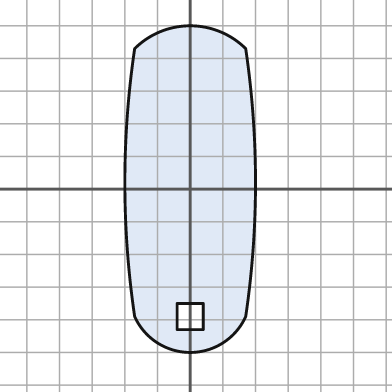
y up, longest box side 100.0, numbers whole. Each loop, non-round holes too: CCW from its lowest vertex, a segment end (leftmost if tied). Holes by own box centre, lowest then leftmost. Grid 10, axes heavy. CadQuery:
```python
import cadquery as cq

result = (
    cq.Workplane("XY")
    .moveTo(-17.0, -39.0)
    .threePointArc((0.0, -50.0), (17.0, -39.0))
    .threePointArc((20.0, 2.0), (17.0, 43.0))
    .threePointArc((0.0, 50.0), (-17.0, 43.0))
    .threePointArc((-20.0, 2.0), (-17.0, -39.0))
    .close()
    .moveTo(-4.0, -43.0)
    .lineTo(4.0, -43.0)
    .lineTo(4.0, -35.0)
    .lineTo(-4.0, -35.0)
    .close()
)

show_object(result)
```